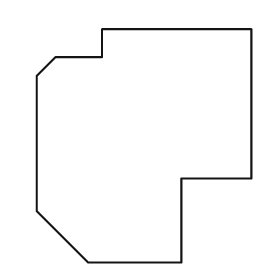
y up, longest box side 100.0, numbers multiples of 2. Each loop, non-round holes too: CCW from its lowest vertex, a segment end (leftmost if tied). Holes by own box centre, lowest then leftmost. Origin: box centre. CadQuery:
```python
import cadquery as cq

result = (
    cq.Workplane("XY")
    .moveTo(-24.0, -50.0)
    .lineTo(16.0, -50.0)
    .lineTo(16.0, -14.0)
    .lineTo(46.0, -14.0)
    .lineTo(46.0, 50.0)
    .lineTo(-18.0, 50.0)
    .lineTo(-18.0, 38.0)
    .lineTo(-38.0, 38.0)
    .lineTo(-46.0, 30.0)
    .lineTo(-46.0, -28.0)
    .close()
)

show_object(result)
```